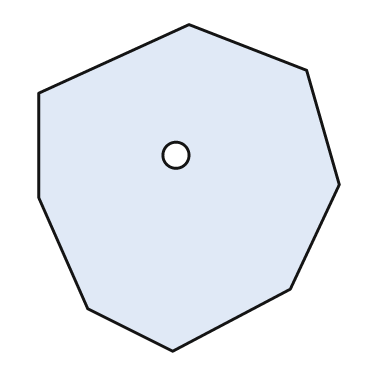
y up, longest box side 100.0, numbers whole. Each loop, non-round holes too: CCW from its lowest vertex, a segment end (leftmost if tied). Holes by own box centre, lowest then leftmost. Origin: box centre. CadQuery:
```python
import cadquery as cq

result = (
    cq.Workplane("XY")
    .moveTo(-5.0, -50.0)
    .lineTo(31.0, -31.0)
    .lineTo(46.0, 1.0)
    .lineTo(36.0, 36.0)
    .lineTo(0.0, 50.0)
    .lineTo(-46.0, 29.0)
    .lineTo(-46.0, -3.0)
    .lineTo(-31.0, -37.0)
    .close()
    .moveTo(-4.0, 10.0)
    .circle(4.0)
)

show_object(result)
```